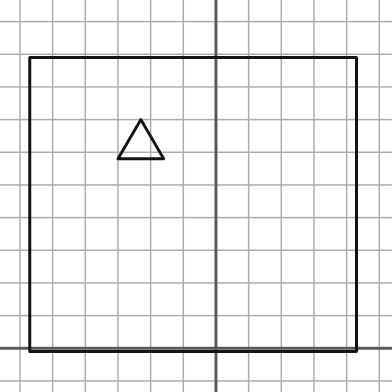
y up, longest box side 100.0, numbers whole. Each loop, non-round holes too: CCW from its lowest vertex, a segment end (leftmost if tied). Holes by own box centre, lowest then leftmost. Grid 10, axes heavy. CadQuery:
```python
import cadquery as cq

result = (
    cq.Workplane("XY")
    .moveTo(-57.0, -1.0)
    .lineTo(43.0, -1.0)
    .lineTo(43.0, 89.0)
    .lineTo(-57.0, 89.0)
    .close()
    .moveTo(-30.0, 58.0)
    .lineTo(-16.0, 58.0)
    .lineTo(-23.0, 70.0)
    .close()
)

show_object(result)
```